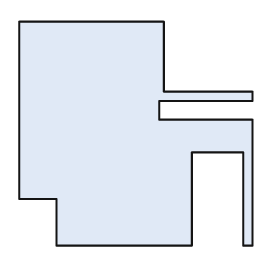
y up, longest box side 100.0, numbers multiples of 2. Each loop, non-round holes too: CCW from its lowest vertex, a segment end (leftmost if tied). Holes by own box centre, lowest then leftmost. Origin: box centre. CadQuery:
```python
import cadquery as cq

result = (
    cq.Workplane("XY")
    .moveTo(-34.0, -48.0)
    .lineTo(24.0, -48.0)
    .lineTo(24.0, -8.0)
    .lineTo(46.0, -8.0)
    .lineTo(46.0, -48.0)
    .lineTo(50.0, -48.0)
    .lineTo(50.0, 6.0)
    .lineTo(10.0, 6.0)
    .lineTo(10.0, 14.0)
    .lineTo(50.0, 14.0)
    .lineTo(50.0, 18.0)
    .lineTo(12.0, 18.0)
    .lineTo(12.0, 48.0)
    .lineTo(-50.0, 48.0)
    .lineTo(-50.0, -28.0)
    .lineTo(-34.0, -28.0)
    .close()
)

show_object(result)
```